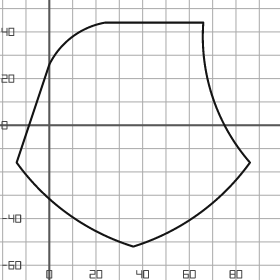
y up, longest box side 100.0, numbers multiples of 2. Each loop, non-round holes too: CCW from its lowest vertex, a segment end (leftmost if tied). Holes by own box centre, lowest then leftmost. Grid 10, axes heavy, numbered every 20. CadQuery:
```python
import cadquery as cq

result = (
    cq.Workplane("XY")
    .moveTo(36.0, -52.0)
    .threePointArc((64.0, -38.0), (86.0, -16.0))
    .threePointArc((70.0, 12.0), (66.0, 44.0))
    .lineTo(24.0, 44.0)
    .threePointArc((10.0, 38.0), (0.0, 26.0))
    .lineTo(-14.0, -16.0)
    .threePointArc((8.0, -38.0), (36.0, -52.0))
    .close()
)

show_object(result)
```